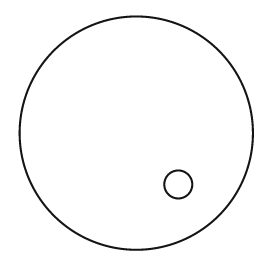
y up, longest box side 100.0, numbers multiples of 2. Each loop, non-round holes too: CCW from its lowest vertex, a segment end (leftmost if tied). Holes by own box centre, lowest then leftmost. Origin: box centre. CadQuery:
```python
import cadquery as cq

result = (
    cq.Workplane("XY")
    .moveTo(0.0, 0.0)
    .circle(50.0)
    .moveTo(18.0, -22.0)
    .circle(6.0)
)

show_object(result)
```